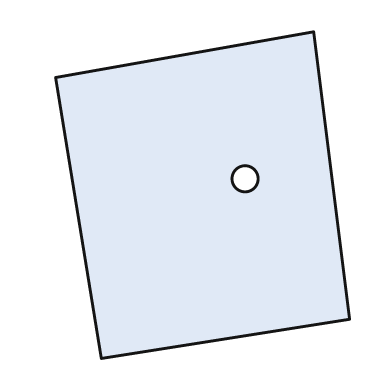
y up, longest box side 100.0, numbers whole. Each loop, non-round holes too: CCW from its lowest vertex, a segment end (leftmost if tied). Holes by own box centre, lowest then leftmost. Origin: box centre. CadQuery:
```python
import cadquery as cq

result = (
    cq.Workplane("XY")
    .moveTo(-31.0, -50.0)
    .lineTo(45.0, -38.0)
    .lineTo(34.0, 50.0)
    .lineTo(-45.0, 36.0)
    .close()
    .moveTo(13.0, 5.0)
    .circle(4.0)
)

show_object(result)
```